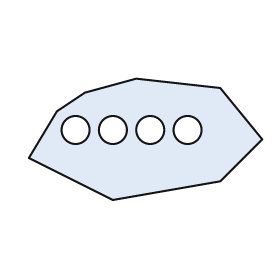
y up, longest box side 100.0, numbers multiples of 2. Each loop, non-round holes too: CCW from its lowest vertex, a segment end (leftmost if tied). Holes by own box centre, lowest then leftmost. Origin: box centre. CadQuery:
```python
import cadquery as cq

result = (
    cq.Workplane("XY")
    .moveTo(-14.0, -26.0)
    .lineTo(32.0, -18.0)
    .lineTo(50.0, 0.0)
    .lineTo(32.0, 22.0)
    .lineTo(-4.0, 26.0)
    .lineTo(-26.0, 20.0)
    .lineTo(-38.0, 12.0)
    .lineTo(-50.0, -8.0)
    .close()
    .moveTo(-30.0, 4.0)
    .circle(6.0)
    .moveTo(-14.0, 4.0)
    .circle(6.0)
    .moveTo(2.0, 4.0)
    .circle(6.0)
    .moveTo(18.0, 4.0)
    .circle(6.0)
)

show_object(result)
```